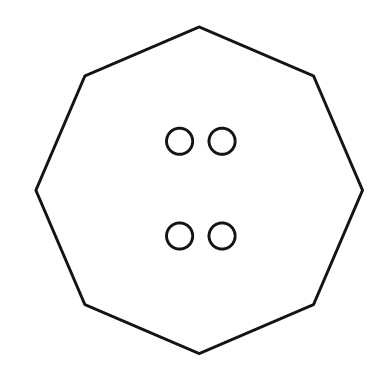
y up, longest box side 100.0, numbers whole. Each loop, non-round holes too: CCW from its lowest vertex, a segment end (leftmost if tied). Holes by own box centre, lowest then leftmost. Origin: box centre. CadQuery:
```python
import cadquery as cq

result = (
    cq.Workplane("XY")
    .moveTo(0.0, -50.0)
    .lineTo(35.0, -35.0)
    .lineTo(50.0, 0.0)
    .lineTo(35.0, 35.0)
    .lineTo(0.0, 50.0)
    .lineTo(-35.0, 35.0)
    .lineTo(-50.0, 0.0)
    .lineTo(-35.0, -35.0)
    .close()
    .moveTo(-6.0, -14.0)
    .circle(4.0)
    .moveTo(7.0, -14.0)
    .circle(4.0)
    .moveTo(-6.0, 15.0)
    .circle(4.0)
    .moveTo(7.0, 15.0)
    .circle(4.0)
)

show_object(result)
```